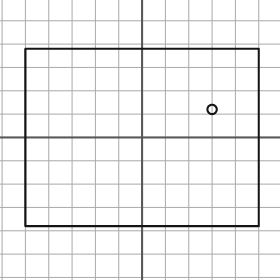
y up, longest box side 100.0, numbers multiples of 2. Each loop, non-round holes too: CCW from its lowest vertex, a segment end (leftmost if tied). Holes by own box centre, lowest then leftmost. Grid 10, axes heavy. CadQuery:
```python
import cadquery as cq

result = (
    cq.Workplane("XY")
    .moveTo(-50.0, -38.0)
    .lineTo(50.0, -38.0)
    .lineTo(50.0, 38.0)
    .lineTo(-50.0, 38.0)
    .close()
    .moveTo(30.0, 12.0)
    .circle(2.0)
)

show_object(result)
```